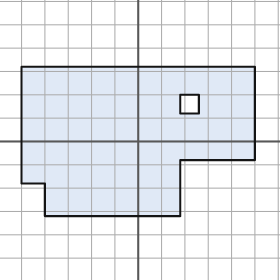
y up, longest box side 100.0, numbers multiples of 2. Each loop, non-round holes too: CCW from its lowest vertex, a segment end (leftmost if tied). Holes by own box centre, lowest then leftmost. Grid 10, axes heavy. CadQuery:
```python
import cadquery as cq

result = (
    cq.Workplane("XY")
    .moveTo(-40.0, -32.0)
    .lineTo(18.0, -32.0)
    .lineTo(18.0, -8.0)
    .lineTo(50.0, -8.0)
    .lineTo(50.0, 32.0)
    .lineTo(-50.0, 32.0)
    .lineTo(-50.0, -18.0)
    .lineTo(-40.0, -18.0)
    .close()
    .moveTo(18.0, 12.0)
    .lineTo(26.0, 12.0)
    .lineTo(26.0, 20.0)
    .lineTo(18.0, 20.0)
    .close()
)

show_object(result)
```